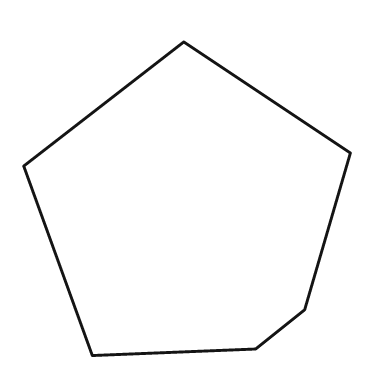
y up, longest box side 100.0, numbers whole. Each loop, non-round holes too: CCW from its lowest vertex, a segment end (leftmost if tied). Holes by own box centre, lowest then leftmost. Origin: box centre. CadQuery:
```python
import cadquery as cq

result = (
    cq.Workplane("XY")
    .moveTo(-29.0, -48.0)
    .lineTo(21.0, -46.0)
    .lineTo(36.0, -34.0)
    .lineTo(50.0, 14.0)
    .lineTo(-1.0, 48.0)
    .lineTo(-50.0, 10.0)
    .close()
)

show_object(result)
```